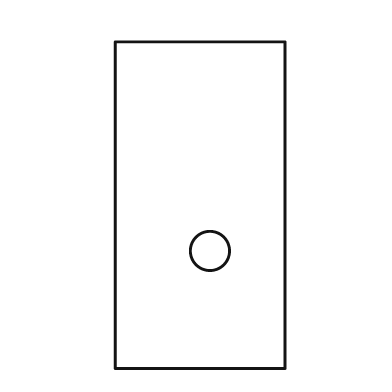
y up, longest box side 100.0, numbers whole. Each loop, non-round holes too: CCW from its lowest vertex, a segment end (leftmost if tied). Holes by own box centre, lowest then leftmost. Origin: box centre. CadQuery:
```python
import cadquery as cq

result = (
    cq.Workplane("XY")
    .moveTo(-26.0, -50.0)
    .lineTo(26.0, -50.0)
    .lineTo(26.0, 50.0)
    .lineTo(-26.0, 50.0)
    .close()
    .moveTo(3.0, -14.0)
    .circle(6.0)
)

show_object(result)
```